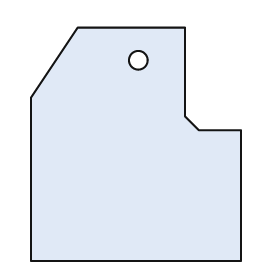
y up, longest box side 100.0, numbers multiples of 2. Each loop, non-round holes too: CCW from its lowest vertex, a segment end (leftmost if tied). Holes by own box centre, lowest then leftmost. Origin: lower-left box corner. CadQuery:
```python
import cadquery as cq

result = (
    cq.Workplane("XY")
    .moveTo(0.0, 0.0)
    .lineTo(90.0, 0.0)
    .lineTo(90.0, 56.0)
    .lineTo(72.0, 56.0)
    .lineTo(66.0, 62.0)
    .lineTo(66.0, 100.0)
    .lineTo(20.0, 100.0)
    .lineTo(0.0, 70.0)
    .close()
    .moveTo(46.0, 86.0)
    .circle(4.0)
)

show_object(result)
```